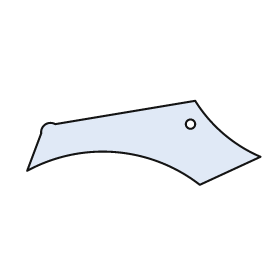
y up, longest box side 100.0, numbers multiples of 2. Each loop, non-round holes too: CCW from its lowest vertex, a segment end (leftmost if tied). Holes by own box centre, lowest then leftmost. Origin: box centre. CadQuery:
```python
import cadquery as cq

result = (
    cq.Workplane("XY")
    .moveTo(24.0, -18.0)
    .lineTo(50.0, -6.0)
    .threePointArc((34.0, 4.0), (22.0, 18.0))
    .lineTo(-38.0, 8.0)
    .threePointArc((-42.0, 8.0), (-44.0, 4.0))
    .lineTo(-50.0, -12.0)
    .threePointArc((-12.0, -4.0), (24.0, -18.0))
    .close()
    .moveTo(20.0, 8.0)
    .circle(2.0)
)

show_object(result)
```